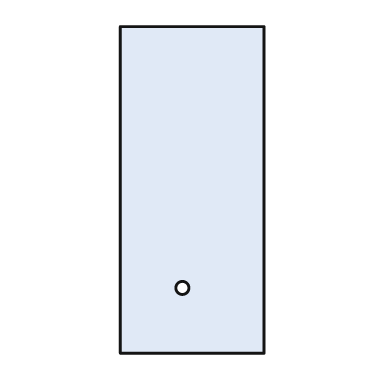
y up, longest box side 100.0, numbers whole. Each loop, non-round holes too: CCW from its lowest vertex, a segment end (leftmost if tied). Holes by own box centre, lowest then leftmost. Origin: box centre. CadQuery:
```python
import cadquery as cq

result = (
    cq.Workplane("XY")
    .moveTo(-22.0, -50.0)
    .lineTo(22.0, -50.0)
    .lineTo(22.0, 50.0)
    .lineTo(-22.0, 50.0)
    .close()
    .moveTo(-3.0, -30.0)
    .circle(2.0)
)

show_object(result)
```